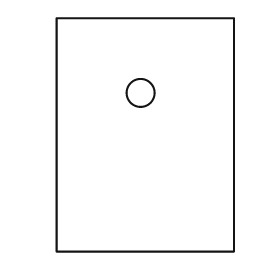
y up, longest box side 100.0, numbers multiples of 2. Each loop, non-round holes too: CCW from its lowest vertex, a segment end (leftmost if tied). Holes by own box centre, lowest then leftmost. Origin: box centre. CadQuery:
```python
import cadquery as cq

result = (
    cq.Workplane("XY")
    .moveTo(-38.0, -50.0)
    .lineTo(38.0, -50.0)
    .lineTo(38.0, 50.0)
    .lineTo(-38.0, 50.0)
    .close()
    .moveTo(-2.0, 18.0)
    .circle(6.0)
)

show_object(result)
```